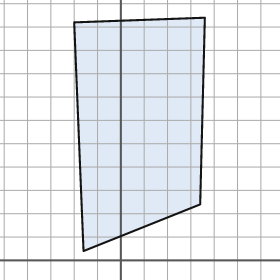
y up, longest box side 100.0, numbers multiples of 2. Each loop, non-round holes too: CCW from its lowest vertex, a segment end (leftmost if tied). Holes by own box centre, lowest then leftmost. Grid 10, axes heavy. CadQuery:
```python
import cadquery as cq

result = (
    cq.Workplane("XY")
    .moveTo(-16.0, 4.0)
    .lineTo(34.0, 24.0)
    .lineTo(36.0, 104.0)
    .lineTo(-20.0, 102.0)
    .close()
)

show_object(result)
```